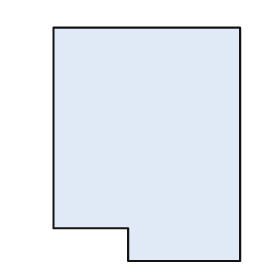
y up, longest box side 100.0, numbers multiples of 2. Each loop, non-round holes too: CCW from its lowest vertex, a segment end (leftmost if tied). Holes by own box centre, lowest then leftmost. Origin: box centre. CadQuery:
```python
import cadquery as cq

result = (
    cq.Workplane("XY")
    .moveTo(-8.0, -50.0)
    .lineTo(40.0, -50.0)
    .lineTo(40.0, 50.0)
    .lineTo(-40.0, 50.0)
    .lineTo(-40.0, -36.0)
    .lineTo(-8.0, -36.0)
    .close()
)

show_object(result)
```